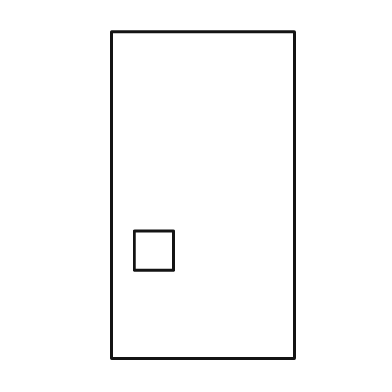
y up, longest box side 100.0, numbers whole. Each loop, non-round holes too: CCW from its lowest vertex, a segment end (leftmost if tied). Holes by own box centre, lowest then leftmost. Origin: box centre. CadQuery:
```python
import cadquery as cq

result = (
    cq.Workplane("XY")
    .moveTo(-28.0, -50.0)
    .lineTo(28.0, -50.0)
    .lineTo(28.0, 50.0)
    .lineTo(-28.0, 50.0)
    .close()
    .moveTo(-21.0, -23.0)
    .lineTo(-9.0, -23.0)
    .lineTo(-9.0, -11.0)
    .lineTo(-21.0, -11.0)
    .close()
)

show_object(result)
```